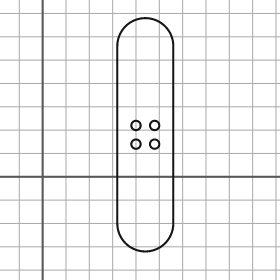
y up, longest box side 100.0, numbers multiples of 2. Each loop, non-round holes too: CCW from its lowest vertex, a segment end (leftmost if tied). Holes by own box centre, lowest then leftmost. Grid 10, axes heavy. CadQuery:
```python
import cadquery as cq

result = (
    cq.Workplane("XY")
    .moveTo(32.0, -20.0)
    .threePointArc((44.0, -32.0), (56.0, -20.0))
    .lineTo(56.0, 56.0)
    .threePointArc((44.0, 68.0), (32.0, 56.0))
    .close()
    .moveTo(40.0, 14.0)
    .circle(2.0)
    .moveTo(48.0, 14.0)
    .circle(2.0)
    .moveTo(40.0, 22.0)
    .circle(2.0)
    .moveTo(48.0, 22.0)
    .circle(2.0)
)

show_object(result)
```